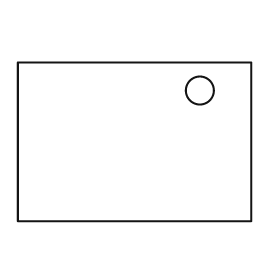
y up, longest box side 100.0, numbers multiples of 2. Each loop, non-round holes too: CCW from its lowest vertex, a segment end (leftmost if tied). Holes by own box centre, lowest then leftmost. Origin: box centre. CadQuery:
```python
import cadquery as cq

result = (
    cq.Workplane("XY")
    .moveTo(-50.0, -34.0)
    .lineTo(50.0, -34.0)
    .lineTo(50.0, 34.0)
    .lineTo(-50.0, 34.0)
    .close()
    .moveTo(28.0, 22.0)
    .circle(6.0)
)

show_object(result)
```